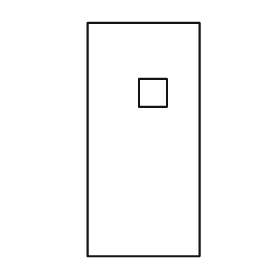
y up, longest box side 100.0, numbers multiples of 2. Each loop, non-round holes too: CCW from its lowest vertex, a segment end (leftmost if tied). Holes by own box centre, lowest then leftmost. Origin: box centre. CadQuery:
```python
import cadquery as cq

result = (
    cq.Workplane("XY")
    .moveTo(-24.0, -50.0)
    .lineTo(24.0, -50.0)
    .lineTo(24.0, 50.0)
    .lineTo(-24.0, 50.0)
    .close()
    .moveTo(-2.0, 14.0)
    .lineTo(10.0, 14.0)
    .lineTo(10.0, 26.0)
    .lineTo(-2.0, 26.0)
    .close()
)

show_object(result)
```